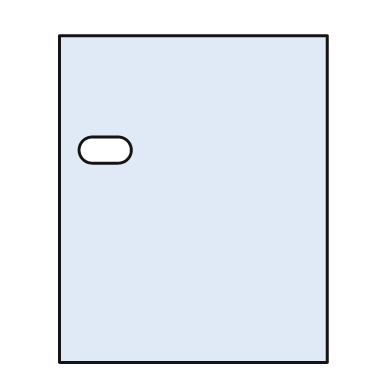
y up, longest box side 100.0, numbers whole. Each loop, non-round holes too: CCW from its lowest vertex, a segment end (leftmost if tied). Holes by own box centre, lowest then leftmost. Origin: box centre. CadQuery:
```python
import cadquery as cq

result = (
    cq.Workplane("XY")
    .moveTo(-41.0, -50.0)
    .lineTo(41.0, -50.0)
    .lineTo(41.0, 50.0)
    .lineTo(-41.0, 50.0)
    .close()
    .moveTo(-31.0, 11.0)
    .lineTo(-23.0, 11.0)
    .threePointArc((-19.0, 15.0), (-23.0, 19.0))
    .lineTo(-31.0, 19.0)
    .threePointArc((-35.0, 15.0), (-31.0, 11.0))
    .close()
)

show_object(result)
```